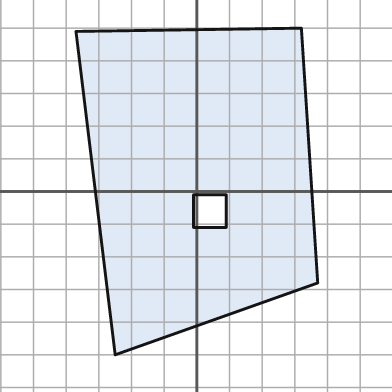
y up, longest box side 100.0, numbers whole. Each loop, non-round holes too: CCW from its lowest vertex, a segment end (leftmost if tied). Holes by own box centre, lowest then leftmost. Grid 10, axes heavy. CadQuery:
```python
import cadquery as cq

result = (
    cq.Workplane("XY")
    .moveTo(-25.0, -50.0)
    .lineTo(37.0, -28.0)
    .lineTo(32.0, 50.0)
    .lineTo(-37.0, 49.0)
    .close()
    .moveTo(-1.0, -11.0)
    .lineTo(9.0, -11.0)
    .lineTo(9.0, -1.0)
    .lineTo(-1.0, -1.0)
    .close()
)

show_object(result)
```